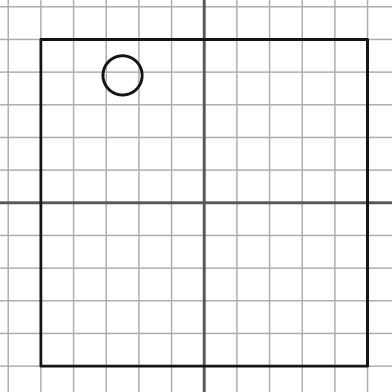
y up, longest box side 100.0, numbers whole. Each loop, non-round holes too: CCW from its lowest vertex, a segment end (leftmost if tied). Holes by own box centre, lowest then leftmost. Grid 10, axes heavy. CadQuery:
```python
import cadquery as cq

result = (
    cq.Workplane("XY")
    .moveTo(-50.0, -50.0)
    .lineTo(50.0, -50.0)
    .lineTo(50.0, 50.0)
    .lineTo(-50.0, 50.0)
    .close()
    .moveTo(-25.0, 39.0)
    .circle(6.0)
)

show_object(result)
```